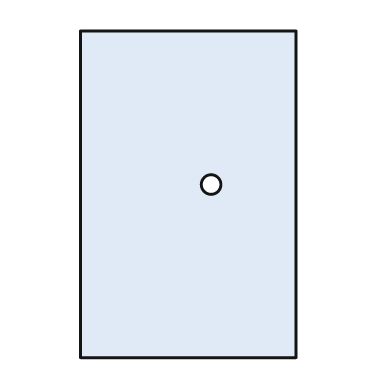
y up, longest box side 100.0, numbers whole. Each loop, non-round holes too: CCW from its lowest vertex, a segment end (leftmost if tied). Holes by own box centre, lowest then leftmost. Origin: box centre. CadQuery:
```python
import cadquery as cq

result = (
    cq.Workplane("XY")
    .moveTo(-33.0, -50.0)
    .lineTo(33.0, -50.0)
    .lineTo(33.0, 50.0)
    .lineTo(-33.0, 50.0)
    .close()
    .moveTo(7.0, 3.0)
    .circle(3.0)
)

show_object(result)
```